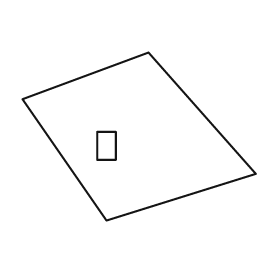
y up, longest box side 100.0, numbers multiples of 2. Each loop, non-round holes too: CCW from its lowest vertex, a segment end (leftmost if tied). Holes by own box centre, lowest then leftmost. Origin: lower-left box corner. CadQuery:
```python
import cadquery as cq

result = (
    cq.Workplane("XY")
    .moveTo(36.0, 0.0)
    .lineTo(100.0, 20.0)
    .lineTo(54.0, 72.0)
    .lineTo(0.0, 52.0)
    .close()
    .moveTo(32.0, 26.0)
    .lineTo(40.0, 26.0)
    .lineTo(40.0, 38.0)
    .lineTo(32.0, 38.0)
    .close()
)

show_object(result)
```